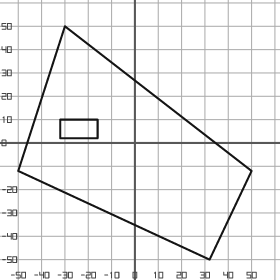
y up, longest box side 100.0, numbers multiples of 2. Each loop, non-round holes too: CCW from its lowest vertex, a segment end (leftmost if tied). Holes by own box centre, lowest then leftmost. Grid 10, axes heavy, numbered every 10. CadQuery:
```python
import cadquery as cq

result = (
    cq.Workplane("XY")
    .moveTo(32.0, -50.0)
    .lineTo(50.0, -12.0)
    .lineTo(-30.0, 50.0)
    .lineTo(-50.0, -12.0)
    .close()
    .moveTo(-32.0, 2.0)
    .lineTo(-16.0, 2.0)
    .lineTo(-16.0, 10.0)
    .lineTo(-32.0, 10.0)
    .close()
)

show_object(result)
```